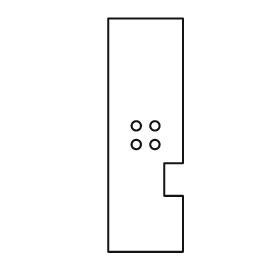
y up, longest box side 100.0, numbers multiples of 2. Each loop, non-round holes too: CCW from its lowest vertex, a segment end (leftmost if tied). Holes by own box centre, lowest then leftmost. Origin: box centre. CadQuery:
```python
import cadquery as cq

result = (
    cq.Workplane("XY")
    .moveTo(-16.0, -50.0)
    .lineTo(16.0, -50.0)
    .lineTo(16.0, -26.0)
    .lineTo(8.0, -26.0)
    .lineTo(8.0, -12.0)
    .lineTo(16.0, -12.0)
    .lineTo(16.0, 50.0)
    .lineTo(-16.0, 50.0)
    .close()
    .moveTo(-4.0, -4.0)
    .circle(2.0)
    .moveTo(4.0, -4.0)
    .circle(2.0)
    .moveTo(-4.0, 4.0)
    .circle(2.0)
    .moveTo(4.0, 4.0)
    .circle(2.0)
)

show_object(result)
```